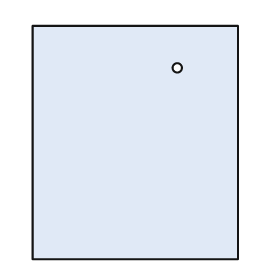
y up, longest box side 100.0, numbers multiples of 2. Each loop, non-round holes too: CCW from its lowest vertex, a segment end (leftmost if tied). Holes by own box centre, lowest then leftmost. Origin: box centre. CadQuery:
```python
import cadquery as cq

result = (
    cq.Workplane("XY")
    .moveTo(-44.0, -50.0)
    .lineTo(44.0, -50.0)
    .lineTo(44.0, 50.0)
    .lineTo(-44.0, 50.0)
    .close()
    .moveTo(18.0, 32.0)
    .circle(2.0)
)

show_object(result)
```